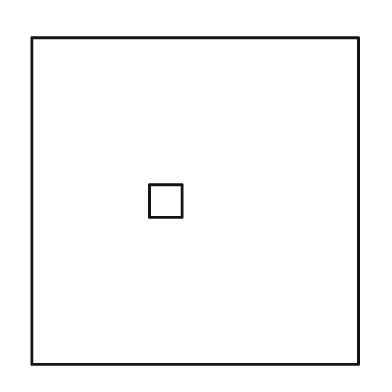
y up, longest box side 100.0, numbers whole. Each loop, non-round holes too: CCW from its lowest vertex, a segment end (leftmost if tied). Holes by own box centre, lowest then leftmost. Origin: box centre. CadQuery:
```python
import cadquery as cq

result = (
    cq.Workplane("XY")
    .moveTo(-50.0, -50.0)
    .lineTo(50.0, -50.0)
    .lineTo(50.0, 50.0)
    .lineTo(-50.0, 50.0)
    .close()
    .moveTo(-14.0, -5.0)
    .lineTo(-4.0, -5.0)
    .lineTo(-4.0, 5.0)
    .lineTo(-14.0, 5.0)
    .close()
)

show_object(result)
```